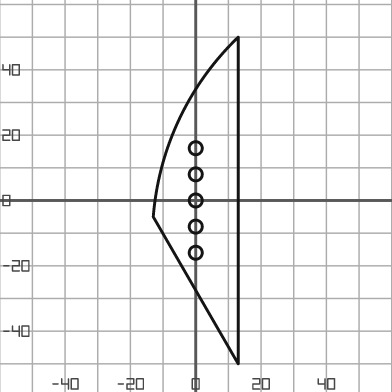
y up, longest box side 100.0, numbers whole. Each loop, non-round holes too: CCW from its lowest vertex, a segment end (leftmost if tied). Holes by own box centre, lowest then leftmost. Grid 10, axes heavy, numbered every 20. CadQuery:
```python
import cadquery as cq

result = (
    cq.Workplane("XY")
    .moveTo(13.0, -50.0)
    .lineTo(13.0, 50.0)
    .threePointArc((-5.0, 25.0), (-13.0, -5.0))
    .close()
    .moveTo(0.0, -16.0)
    .circle(2.0)
    .moveTo(0.0, -8.0)
    .circle(2.0)
    .moveTo(0.0, 0.0)
    .circle(2.0)
    .moveTo(0.0, 8.0)
    .circle(2.0)
    .moveTo(0.0, 16.0)
    .circle(2.0)
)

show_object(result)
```